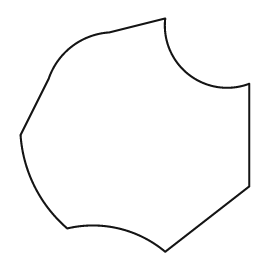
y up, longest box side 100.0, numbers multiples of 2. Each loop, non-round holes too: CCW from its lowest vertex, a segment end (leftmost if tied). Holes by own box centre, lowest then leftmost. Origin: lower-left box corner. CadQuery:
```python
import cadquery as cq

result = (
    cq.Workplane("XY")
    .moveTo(62.0, 0.0)
    .lineTo(98.0, 28.0)
    .lineTo(98.0, 72.0)
    .threePointArc((72.0, 76.0), (62.0, 100.0))
    .lineTo(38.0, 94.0)
    .threePointArc((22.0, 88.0), (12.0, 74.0))
    .lineTo(0.0, 50.0)
    .threePointArc((6.0, 28.0), (20.0, 10.0))
    .threePointArc((42.0, 10.0), (62.0, 0.0))
    .close()
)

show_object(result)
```